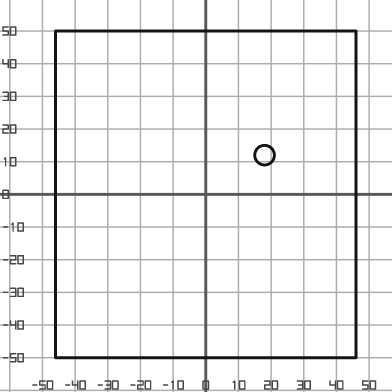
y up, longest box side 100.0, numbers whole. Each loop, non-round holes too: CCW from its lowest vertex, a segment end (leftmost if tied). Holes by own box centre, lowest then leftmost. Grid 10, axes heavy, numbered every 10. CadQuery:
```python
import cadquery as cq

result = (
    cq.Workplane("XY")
    .moveTo(-46.0, -50.0)
    .lineTo(46.0, -50.0)
    .lineTo(46.0, 50.0)
    .lineTo(-46.0, 50.0)
    .close()
    .moveTo(18.0, 12.0)
    .circle(3.0)
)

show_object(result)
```